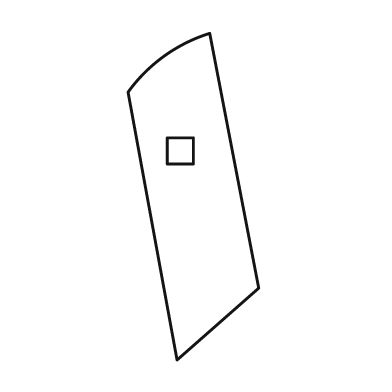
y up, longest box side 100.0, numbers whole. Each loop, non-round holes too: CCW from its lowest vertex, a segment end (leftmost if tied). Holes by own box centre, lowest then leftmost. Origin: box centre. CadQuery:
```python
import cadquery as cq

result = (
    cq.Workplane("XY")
    .moveTo(-5.0, -50.0)
    .lineTo(20.0, -28.0)
    .lineTo(5.0, 50.0)
    .threePointArc((-9.0, 43.0), (-20.0, 32.0))
    .close()
    .moveTo(-8.0, 10.0)
    .lineTo(0.0, 10.0)
    .lineTo(0.0, 18.0)
    .lineTo(-8.0, 18.0)
    .close()
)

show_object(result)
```